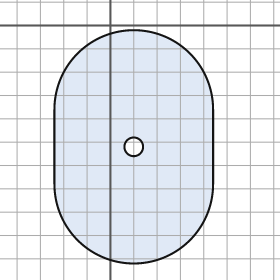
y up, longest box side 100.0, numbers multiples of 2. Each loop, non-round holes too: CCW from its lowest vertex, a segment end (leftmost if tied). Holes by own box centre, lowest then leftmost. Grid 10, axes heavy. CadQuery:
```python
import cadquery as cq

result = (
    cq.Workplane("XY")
    .moveTo(-24.0, -68.0)
    .threePointArc((10.0, -102.0), (44.0, -68.0))
    .lineTo(44.0, -36.0)
    .threePointArc((10.0, -2.0), (-24.0, -36.0))
    .close()
    .moveTo(10.0, -52.0)
    .circle(4.0)
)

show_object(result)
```